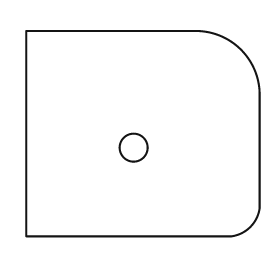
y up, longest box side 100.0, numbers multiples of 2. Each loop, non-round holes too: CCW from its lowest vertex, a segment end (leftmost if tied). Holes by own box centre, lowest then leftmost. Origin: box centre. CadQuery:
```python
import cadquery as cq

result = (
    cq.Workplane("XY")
    .moveTo(-50.0, -44.0)
    .lineTo(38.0, -44.0)
    .threePointArc((46.0, -40.0), (50.0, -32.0))
    .lineTo(50.0, 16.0)
    .threePointArc((42.0, 36.0), (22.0, 44.0))
    .lineTo(-50.0, 44.0)
    .close()
    .moveTo(-4.0, -6.0)
    .circle(6.0)
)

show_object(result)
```